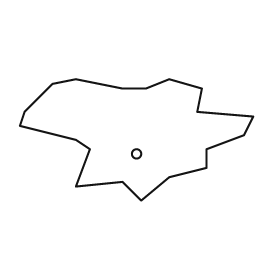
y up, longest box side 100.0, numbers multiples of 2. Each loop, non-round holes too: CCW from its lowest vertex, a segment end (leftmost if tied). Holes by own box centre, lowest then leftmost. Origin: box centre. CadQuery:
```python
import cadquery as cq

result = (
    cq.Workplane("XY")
    .moveTo(2.0, -26.0)
    .lineTo(14.0, -16.0)
    .lineTo(30.0, -12.0)
    .lineTo(30.0, -4.0)
    .lineTo(46.0, 2.0)
    .lineTo(50.0, 10.0)
    .lineTo(26.0, 12.0)
    .lineTo(28.0, 22.0)
    .lineTo(14.0, 26.0)
    .lineTo(4.0, 22.0)
    .lineTo(-6.0, 22.0)
    .lineTo(-26.0, 26.0)
    .lineTo(-36.0, 24.0)
    .lineTo(-48.0, 12.0)
    .lineTo(-50.0, 6.0)
    .lineTo(-26.0, 0.0)
    .lineTo(-20.0, -4.0)
    .lineTo(-26.0, -20.0)
    .lineTo(-6.0, -18.0)
    .close()
    .moveTo(0.0, -6.0)
    .circle(2.0)
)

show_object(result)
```